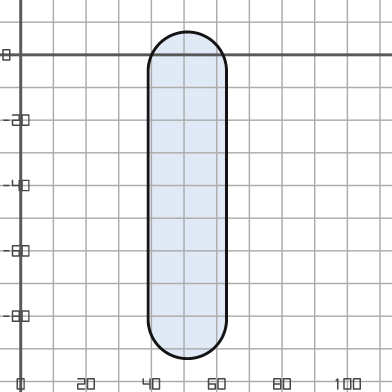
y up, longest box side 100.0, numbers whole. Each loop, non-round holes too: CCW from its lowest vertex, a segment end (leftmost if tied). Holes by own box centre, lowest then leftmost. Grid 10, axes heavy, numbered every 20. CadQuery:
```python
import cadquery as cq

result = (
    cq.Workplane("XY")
    .moveTo(39.0, -81.0)
    .threePointArc((51.0, -93.0), (63.0, -81.0))
    .lineTo(63.0, -5.0)
    .threePointArc((51.0, 7.0), (39.0, -5.0))
    .close()
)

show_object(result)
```